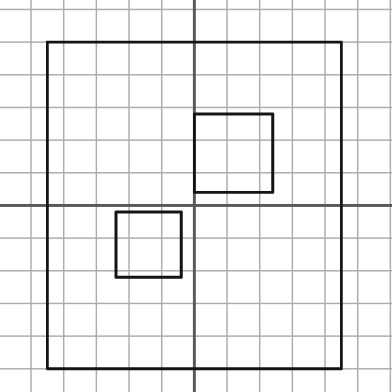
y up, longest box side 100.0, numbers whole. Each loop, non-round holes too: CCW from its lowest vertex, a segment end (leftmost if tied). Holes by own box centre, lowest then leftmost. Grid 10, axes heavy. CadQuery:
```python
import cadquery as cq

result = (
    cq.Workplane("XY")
    .moveTo(-45.0, -50.0)
    .lineTo(45.0, -50.0)
    .lineTo(45.0, 50.0)
    .lineTo(-45.0, 50.0)
    .close()
    .moveTo(-24.0, -22.0)
    .lineTo(-4.0, -22.0)
    .lineTo(-4.0, -2.0)
    .lineTo(-24.0, -2.0)
    .close()
    .moveTo(0.0, 4.0)
    .lineTo(24.0, 4.0)
    .lineTo(24.0, 28.0)
    .lineTo(0.0, 28.0)
    .close()
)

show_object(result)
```